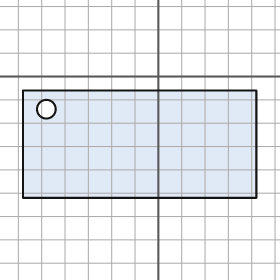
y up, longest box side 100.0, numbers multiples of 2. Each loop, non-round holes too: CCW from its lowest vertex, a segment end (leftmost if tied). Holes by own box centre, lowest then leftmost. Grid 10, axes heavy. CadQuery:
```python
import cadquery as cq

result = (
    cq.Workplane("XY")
    .moveTo(-58.0, -52.0)
    .lineTo(42.0, -52.0)
    .lineTo(42.0, -6.0)
    .lineTo(-58.0, -6.0)
    .close()
    .moveTo(-48.0, -14.0)
    .circle(4.0)
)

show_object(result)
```